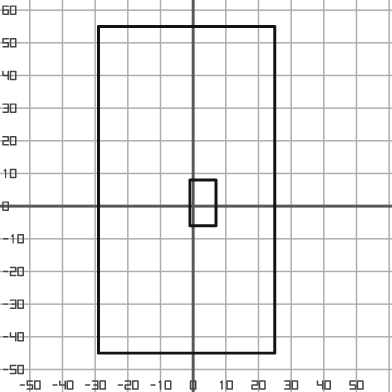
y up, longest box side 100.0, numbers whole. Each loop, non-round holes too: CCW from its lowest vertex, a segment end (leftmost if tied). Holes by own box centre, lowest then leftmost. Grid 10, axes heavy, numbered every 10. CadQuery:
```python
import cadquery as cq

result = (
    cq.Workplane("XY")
    .moveTo(-29.0, -45.0)
    .lineTo(25.0, -45.0)
    .lineTo(25.0, 55.0)
    .lineTo(-29.0, 55.0)
    .close()
    .moveTo(-1.0, -6.0)
    .lineTo(7.0, -6.0)
    .lineTo(7.0, 8.0)
    .lineTo(-1.0, 8.0)
    .close()
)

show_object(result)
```